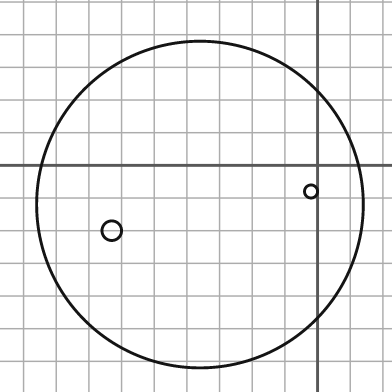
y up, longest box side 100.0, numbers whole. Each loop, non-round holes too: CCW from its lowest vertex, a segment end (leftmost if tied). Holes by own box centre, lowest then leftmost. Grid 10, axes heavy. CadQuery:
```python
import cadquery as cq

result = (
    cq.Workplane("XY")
    .moveTo(-36.0, -12.0)
    .circle(50.0)
    .moveTo(-63.0, -20.0)
    .circle(3.0)
    .moveTo(-2.0, -8.0)
    .circle(2.0)
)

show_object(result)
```